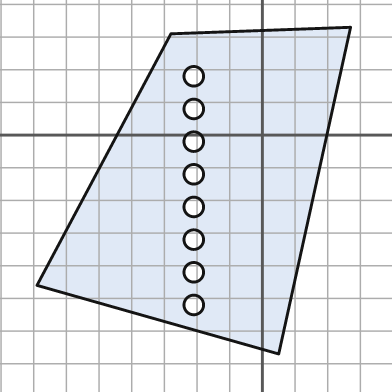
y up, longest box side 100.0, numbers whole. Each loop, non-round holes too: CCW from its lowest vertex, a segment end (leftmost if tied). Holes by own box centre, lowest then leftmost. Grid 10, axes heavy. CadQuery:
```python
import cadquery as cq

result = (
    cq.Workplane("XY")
    .moveTo(5.0, -67.0)
    .lineTo(27.0, 33.0)
    .lineTo(-28.0, 31.0)
    .lineTo(-69.0, -46.0)
    .close()
    .moveTo(-21.0, -52.0)
    .circle(3.0)
    .moveTo(-21.0, -42.0)
    .circle(3.0)
    .moveTo(-21.0, -32.0)
    .circle(3.0)
    .moveTo(-21.0, -22.0)
    .circle(3.0)
    .moveTo(-21.0, -12.0)
    .circle(3.0)
    .moveTo(-21.0, -2.0)
    .circle(3.0)
    .moveTo(-21.0, 8.0)
    .circle(3.0)
    .moveTo(-21.0, 18.0)
    .circle(3.0)
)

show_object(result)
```